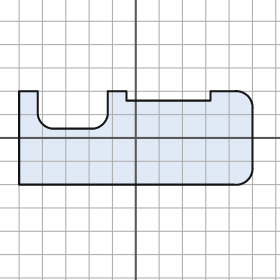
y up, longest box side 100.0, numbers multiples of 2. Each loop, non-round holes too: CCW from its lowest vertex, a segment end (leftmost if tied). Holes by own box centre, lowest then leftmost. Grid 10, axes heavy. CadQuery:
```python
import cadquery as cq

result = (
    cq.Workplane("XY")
    .moveTo(-50.0, -20.0)
    .lineTo(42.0, -20.0)
    .threePointArc((48.0, -18.0), (50.0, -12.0))
    .lineTo(50.0, 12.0)
    .threePointArc((48.0, 18.0), (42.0, 20.0))
    .lineTo(32.0, 20.0)
    .lineTo(32.0, 16.0)
    .lineTo(-4.0, 16.0)
    .lineTo(-4.0, 20.0)
    .lineTo(-12.0, 20.0)
    .lineTo(-12.0, 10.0)
    .threePointArc((-14.0, 6.0), (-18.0, 4.0))
    .lineTo(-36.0, 4.0)
    .threePointArc((-40.0, 6.0), (-42.0, 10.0))
    .lineTo(-42.0, 20.0)
    .lineTo(-50.0, 20.0)
    .close()
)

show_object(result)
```